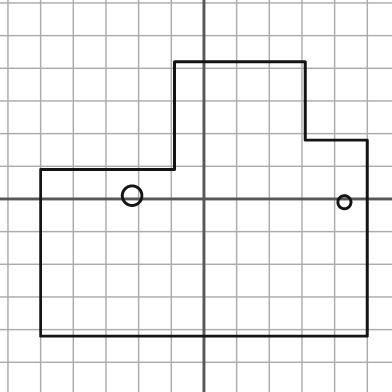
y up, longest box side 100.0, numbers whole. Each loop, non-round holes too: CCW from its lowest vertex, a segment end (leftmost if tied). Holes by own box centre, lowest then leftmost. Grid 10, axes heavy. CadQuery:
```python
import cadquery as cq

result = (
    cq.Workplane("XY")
    .moveTo(-50.0, -42.0)
    .lineTo(50.0, -42.0)
    .lineTo(50.0, 18.0)
    .lineTo(31.0, 18.0)
    .lineTo(31.0, 42.0)
    .lineTo(-9.0, 42.0)
    .lineTo(-9.0, 9.0)
    .lineTo(-50.0, 9.0)
    .close()
    .moveTo(43.0, -1.0)
    .circle(2.0)
    .moveTo(-22.0, 1.0)
    .circle(3.0)
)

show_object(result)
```